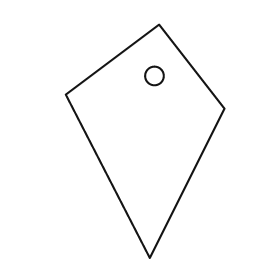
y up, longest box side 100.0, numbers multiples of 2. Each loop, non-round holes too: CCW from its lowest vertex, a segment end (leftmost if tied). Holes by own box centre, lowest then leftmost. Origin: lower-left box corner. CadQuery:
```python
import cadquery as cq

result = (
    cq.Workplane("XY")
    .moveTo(36.0, 0.0)
    .lineTo(68.0, 64.0)
    .lineTo(40.0, 100.0)
    .lineTo(0.0, 70.0)
    .close()
    .moveTo(38.0, 78.0)
    .circle(4.0)
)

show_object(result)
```